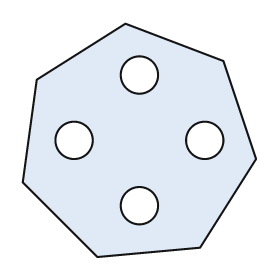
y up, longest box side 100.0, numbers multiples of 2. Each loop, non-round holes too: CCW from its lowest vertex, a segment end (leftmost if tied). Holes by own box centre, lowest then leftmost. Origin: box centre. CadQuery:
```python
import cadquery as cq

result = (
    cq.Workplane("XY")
    .moveTo(-18.0, -50.0)
    .lineTo(26.0, -46.0)
    .lineTo(50.0, -8.0)
    .lineTo(36.0, 34.0)
    .lineTo(-6.0, 50.0)
    .lineTo(-44.0, 26.0)
    .lineTo(-50.0, -18.0)
    .close()
    .moveTo(0.0, -28.0)
    .circle(8.0)
    .moveTo(-28.0, 0.0)
    .circle(8.0)
    .moveTo(28.0, 0.0)
    .circle(8.0)
    .moveTo(0.0, 28.0)
    .circle(8.0)
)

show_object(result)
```